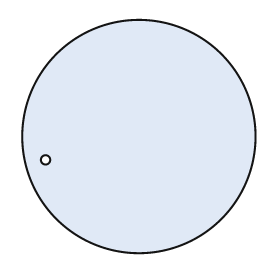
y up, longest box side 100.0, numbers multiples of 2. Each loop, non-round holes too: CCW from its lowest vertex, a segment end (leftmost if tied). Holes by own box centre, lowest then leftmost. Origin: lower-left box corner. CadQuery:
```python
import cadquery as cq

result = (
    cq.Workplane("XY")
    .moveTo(50.0, 50.0)
    .circle(50.0)
    .moveTo(10.0, 40.0)
    .circle(2.0)
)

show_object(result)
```